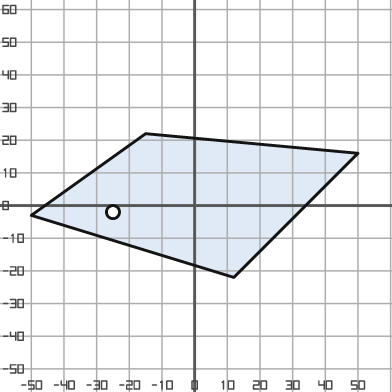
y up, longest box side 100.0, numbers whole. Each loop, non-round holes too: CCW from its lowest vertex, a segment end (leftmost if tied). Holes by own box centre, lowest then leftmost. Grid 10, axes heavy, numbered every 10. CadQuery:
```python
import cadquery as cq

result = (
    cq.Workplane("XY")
    .moveTo(12.0, -22.0)
    .lineTo(50.0, 16.0)
    .lineTo(-15.0, 22.0)
    .lineTo(-50.0, -3.0)
    .close()
    .moveTo(-25.0, -2.0)
    .circle(2.0)
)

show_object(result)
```